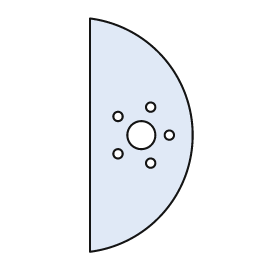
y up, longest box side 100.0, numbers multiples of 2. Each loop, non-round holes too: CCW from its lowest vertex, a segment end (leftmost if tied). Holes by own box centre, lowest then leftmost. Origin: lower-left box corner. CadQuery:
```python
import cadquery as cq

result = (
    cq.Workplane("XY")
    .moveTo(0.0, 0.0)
    .threePointArc((44.0, 50.0), (0.0, 100.0))
    .close()
    .moveTo(26.0, 38.0)
    .circle(2.0)
    .moveTo(12.0, 42.0)
    .circle(2.0)
    .moveTo(22.0, 50.0)
    .circle(6.0)
    .moveTo(34.0, 50.0)
    .circle(2.0)
    .moveTo(12.0, 58.0)
    .circle(2.0)
    .moveTo(26.0, 62.0)
    .circle(2.0)
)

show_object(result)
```